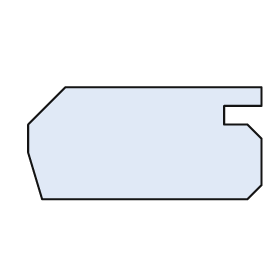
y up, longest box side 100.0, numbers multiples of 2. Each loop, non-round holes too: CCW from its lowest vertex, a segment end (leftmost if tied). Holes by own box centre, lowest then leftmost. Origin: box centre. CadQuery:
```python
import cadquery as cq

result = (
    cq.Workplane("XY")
    .moveTo(-44.0, -24.0)
    .lineTo(44.0, -24.0)
    .lineTo(50.0, -18.0)
    .lineTo(50.0, 2.0)
    .lineTo(44.0, 8.0)
    .lineTo(34.0, 8.0)
    .lineTo(34.0, 16.0)
    .lineTo(50.0, 16.0)
    .lineTo(50.0, 24.0)
    .lineTo(-34.0, 24.0)
    .lineTo(-50.0, 8.0)
    .lineTo(-50.0, -4.0)
    .close()
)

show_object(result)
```